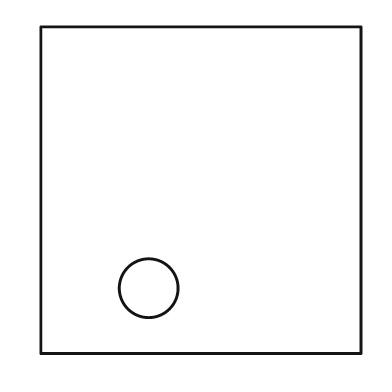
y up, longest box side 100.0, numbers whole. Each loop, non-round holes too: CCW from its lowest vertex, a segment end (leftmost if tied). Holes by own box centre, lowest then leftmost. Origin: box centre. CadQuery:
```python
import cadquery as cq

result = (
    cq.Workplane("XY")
    .moveTo(-49.0, -50.0)
    .lineTo(49.0, -50.0)
    .lineTo(49.0, 50.0)
    .lineTo(-49.0, 50.0)
    .close()
    .moveTo(-16.0, -30.0)
    .circle(9.0)
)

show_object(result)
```